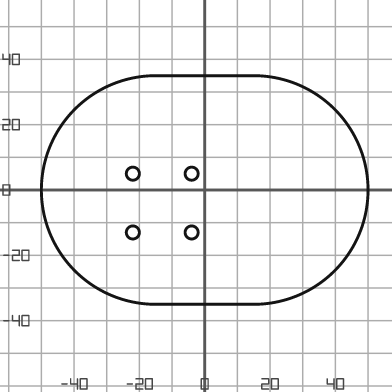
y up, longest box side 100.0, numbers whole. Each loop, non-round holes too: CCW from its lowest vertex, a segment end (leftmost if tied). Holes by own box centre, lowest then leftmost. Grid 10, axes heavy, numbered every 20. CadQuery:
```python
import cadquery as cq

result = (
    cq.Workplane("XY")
    .moveTo(-15.0, -35.0)
    .lineTo(15.0, -35.0)
    .threePointArc((50.0, 0.0), (15.0, 35.0))
    .lineTo(-15.0, 35.0)
    .threePointArc((-50.0, 0.0), (-15.0, -35.0))
    .close()
    .moveTo(-22.0, -13.0)
    .circle(2.0)
    .moveTo(-4.0, -13.0)
    .circle(2.0)
    .moveTo(-22.0, 5.0)
    .circle(2.0)
    .moveTo(-4.0, 5.0)
    .circle(2.0)
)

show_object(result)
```